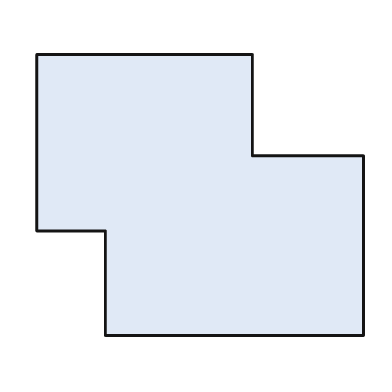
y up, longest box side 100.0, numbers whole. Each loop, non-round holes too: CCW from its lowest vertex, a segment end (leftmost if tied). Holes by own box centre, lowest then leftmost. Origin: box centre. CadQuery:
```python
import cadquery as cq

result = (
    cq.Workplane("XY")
    .moveTo(-29.0, -43.0)
    .lineTo(50.0, -43.0)
    .lineTo(50.0, 12.0)
    .lineTo(16.0, 12.0)
    .lineTo(16.0, 43.0)
    .lineTo(-50.0, 43.0)
    .lineTo(-50.0, -11.0)
    .lineTo(-29.0, -11.0)
    .close()
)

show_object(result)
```